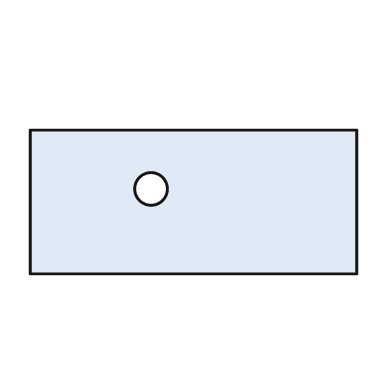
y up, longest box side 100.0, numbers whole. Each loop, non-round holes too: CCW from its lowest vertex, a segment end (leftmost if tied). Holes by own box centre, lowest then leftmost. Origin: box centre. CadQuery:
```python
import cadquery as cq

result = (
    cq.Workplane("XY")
    .moveTo(-50.0, -22.0)
    .lineTo(50.0, -22.0)
    .lineTo(50.0, 22.0)
    .lineTo(-50.0, 22.0)
    .close()
    .moveTo(-13.0, 4.0)
    .circle(5.0)
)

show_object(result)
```